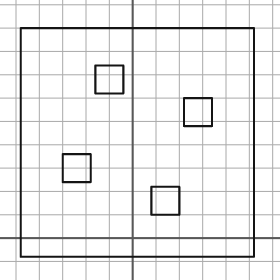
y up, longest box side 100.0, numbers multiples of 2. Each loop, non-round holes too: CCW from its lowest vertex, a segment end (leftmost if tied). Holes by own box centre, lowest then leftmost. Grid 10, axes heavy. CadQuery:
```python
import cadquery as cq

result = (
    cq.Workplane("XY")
    .moveTo(-48.0, -8.0)
    .lineTo(52.0, -8.0)
    .lineTo(52.0, 90.0)
    .lineTo(-48.0, 90.0)
    .close()
    .moveTo(8.0, 10.0)
    .lineTo(20.0, 10.0)
    .lineTo(20.0, 22.0)
    .lineTo(8.0, 22.0)
    .close()
    .moveTo(-30.0, 24.0)
    .lineTo(-18.0, 24.0)
    .lineTo(-18.0, 36.0)
    .lineTo(-30.0, 36.0)
    .close()
    .moveTo(22.0, 48.0)
    .lineTo(34.0, 48.0)
    .lineTo(34.0, 60.0)
    .lineTo(22.0, 60.0)
    .close()
    .moveTo(-16.0, 62.0)
    .lineTo(-4.0, 62.0)
    .lineTo(-4.0, 74.0)
    .lineTo(-16.0, 74.0)
    .close()
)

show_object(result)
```